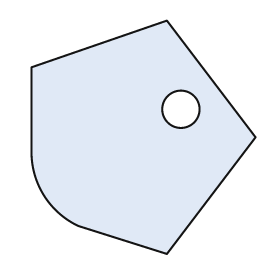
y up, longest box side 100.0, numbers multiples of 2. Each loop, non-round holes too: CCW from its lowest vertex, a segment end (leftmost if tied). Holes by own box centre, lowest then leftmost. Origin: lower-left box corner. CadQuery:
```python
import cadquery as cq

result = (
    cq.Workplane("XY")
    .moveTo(58.0, 0.0)
    .lineTo(96.0, 50.0)
    .lineTo(58.0, 100.0)
    .lineTo(0.0, 80.0)
    .lineTo(0.0, 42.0)
    .threePointArc((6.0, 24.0), (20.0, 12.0))
    .close()
    .moveTo(64.0, 62.0)
    .circle(8.0)
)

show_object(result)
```